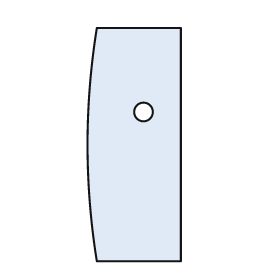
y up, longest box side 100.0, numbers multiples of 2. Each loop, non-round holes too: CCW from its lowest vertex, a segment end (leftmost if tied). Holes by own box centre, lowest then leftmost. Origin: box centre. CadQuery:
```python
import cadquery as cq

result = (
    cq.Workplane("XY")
    .moveTo(-16.0, -50.0)
    .lineTo(20.0, -50.0)
    .lineTo(20.0, 50.0)
    .lineTo(-16.0, 50.0)
    .threePointArc((-20.0, 0.0), (-16.0, -50.0))
    .close()
    .moveTo(4.0, 14.0)
    .circle(4.0)
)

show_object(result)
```